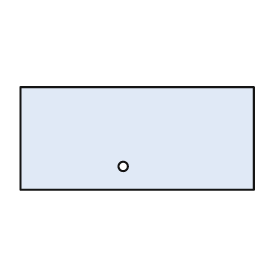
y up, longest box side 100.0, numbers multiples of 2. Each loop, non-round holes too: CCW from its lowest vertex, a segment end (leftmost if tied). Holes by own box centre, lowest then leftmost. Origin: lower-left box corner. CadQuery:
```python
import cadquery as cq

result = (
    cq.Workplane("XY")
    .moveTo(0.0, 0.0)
    .lineTo(100.0, 0.0)
    .lineTo(100.0, 44.0)
    .lineTo(0.0, 44.0)
    .close()
    .moveTo(44.0, 10.0)
    .circle(2.0)
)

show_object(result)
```